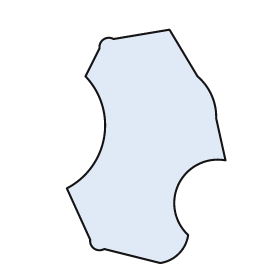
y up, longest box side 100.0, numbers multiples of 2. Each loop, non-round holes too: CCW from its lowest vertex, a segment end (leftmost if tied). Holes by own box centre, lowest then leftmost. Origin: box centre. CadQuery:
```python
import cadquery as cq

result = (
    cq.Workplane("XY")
    .moveTo(6.0, -50.0)
    .threePointArc((14.0, -46.0), (18.0, -38.0))
    .threePointArc((14.0, -16.0), (34.0, -6.0))
    .lineTo(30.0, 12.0)
    .threePointArc((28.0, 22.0), (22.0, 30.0))
    .lineTo(10.0, 50.0)
    .lineTo(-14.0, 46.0)
    .threePointArc((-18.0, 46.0), (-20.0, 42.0))
    .lineTo(-26.0, 30.0)
    .threePointArc((-18.0, 4.0), (-34.0, -18.0))
    .lineTo(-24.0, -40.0)
    .threePointArc((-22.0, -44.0), (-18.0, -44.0))
    .close()
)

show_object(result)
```